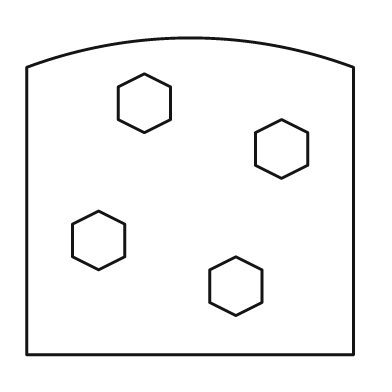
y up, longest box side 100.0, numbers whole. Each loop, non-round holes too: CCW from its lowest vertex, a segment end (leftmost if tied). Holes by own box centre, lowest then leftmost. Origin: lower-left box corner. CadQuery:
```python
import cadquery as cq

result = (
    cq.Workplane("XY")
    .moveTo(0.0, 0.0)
    .lineTo(100.0, 0.0)
    .lineTo(100.0, 88.0)
    .threePointArc((50.0, 97.0), (0.0, 88.0))
    .close()
    .moveTo(64.0, 12.0)
    .lineTo(72.0, 16.0)
    .lineTo(72.0, 26.0)
    .lineTo(64.0, 30.0)
    .lineTo(56.0, 26.0)
    .lineTo(56.0, 16.0)
    .close()
    .moveTo(22.0, 26.0)
    .lineTo(30.0, 30.0)
    .lineTo(30.0, 40.0)
    .lineTo(22.0, 44.0)
    .lineTo(14.0, 40.0)
    .lineTo(14.0, 30.0)
    .close()
    .moveTo(78.0, 54.0)
    .lineTo(86.0, 58.0)
    .lineTo(86.0, 68.0)
    .lineTo(78.0, 72.0)
    .lineTo(70.0, 68.0)
    .lineTo(70.0, 58.0)
    .close()
    .moveTo(36.0, 68.0)
    .lineTo(44.0, 72.0)
    .lineTo(44.0, 82.0)
    .lineTo(36.0, 86.0)
    .lineTo(28.0, 82.0)
    .lineTo(28.0, 72.0)
    .close()
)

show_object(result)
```